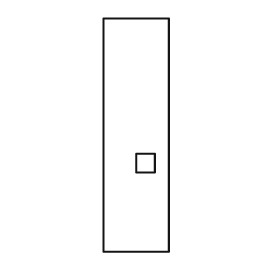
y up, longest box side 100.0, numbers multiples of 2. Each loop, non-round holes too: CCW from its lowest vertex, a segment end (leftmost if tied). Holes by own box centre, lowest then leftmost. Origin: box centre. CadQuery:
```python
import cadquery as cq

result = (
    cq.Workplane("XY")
    .moveTo(-14.0, -50.0)
    .lineTo(14.0, -50.0)
    .lineTo(14.0, 50.0)
    .lineTo(-14.0, 50.0)
    .close()
    .moveTo(0.0, -16.0)
    .lineTo(8.0, -16.0)
    .lineTo(8.0, -8.0)
    .lineTo(0.0, -8.0)
    .close()
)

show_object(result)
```